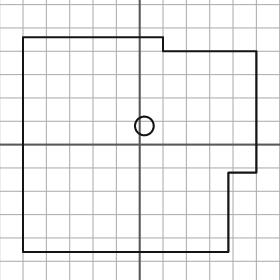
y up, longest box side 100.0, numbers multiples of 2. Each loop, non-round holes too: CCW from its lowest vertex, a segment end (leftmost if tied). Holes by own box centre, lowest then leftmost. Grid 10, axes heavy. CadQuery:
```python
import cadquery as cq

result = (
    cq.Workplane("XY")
    .moveTo(-50.0, -46.0)
    .lineTo(38.0, -46.0)
    .lineTo(38.0, -12.0)
    .lineTo(50.0, -12.0)
    .lineTo(50.0, 40.0)
    .lineTo(10.0, 40.0)
    .lineTo(10.0, 46.0)
    .lineTo(-50.0, 46.0)
    .close()
    .moveTo(2.0, 8.0)
    .circle(4.0)
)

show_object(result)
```